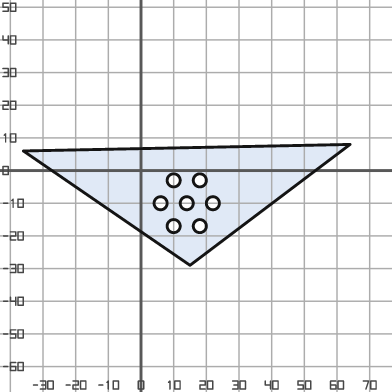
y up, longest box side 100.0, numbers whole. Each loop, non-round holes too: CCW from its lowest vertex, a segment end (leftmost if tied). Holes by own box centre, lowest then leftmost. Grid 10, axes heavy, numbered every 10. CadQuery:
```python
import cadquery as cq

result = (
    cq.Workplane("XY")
    .moveTo(15.0, -29.0)
    .lineTo(64.0, 8.0)
    .lineTo(-36.0, 6.0)
    .close()
    .moveTo(10.0, -17.0)
    .circle(2.0)
    .moveTo(18.0, -17.0)
    .circle(2.0)
    .moveTo(6.0, -10.0)
    .circle(2.0)
    .moveTo(14.0, -10.0)
    .circle(2.0)
    .moveTo(22.0, -10.0)
    .circle(2.0)
    .moveTo(10.0, -3.0)
    .circle(2.0)
    .moveTo(18.0, -3.0)
    .circle(2.0)
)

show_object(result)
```